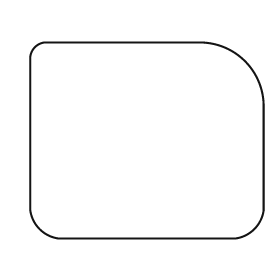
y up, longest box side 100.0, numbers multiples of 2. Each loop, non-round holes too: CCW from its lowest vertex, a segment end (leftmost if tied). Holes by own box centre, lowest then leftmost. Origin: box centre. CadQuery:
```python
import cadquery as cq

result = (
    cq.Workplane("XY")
    .moveTo(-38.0, -42.0)
    .lineTo(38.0, -42.0)
    .threePointArc((46.0, -38.0), (50.0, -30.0))
    .lineTo(50.0, 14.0)
    .threePointArc((42.0, 34.0), (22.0, 42.0))
    .lineTo(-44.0, 42.0)
    .threePointArc((-48.0, 40.0), (-50.0, 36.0))
    .lineTo(-50.0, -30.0)
    .threePointArc((-46.0, -38.0), (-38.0, -42.0))
    .close()
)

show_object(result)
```